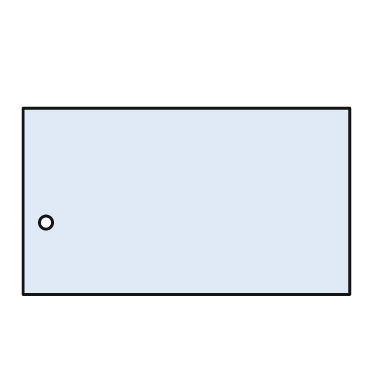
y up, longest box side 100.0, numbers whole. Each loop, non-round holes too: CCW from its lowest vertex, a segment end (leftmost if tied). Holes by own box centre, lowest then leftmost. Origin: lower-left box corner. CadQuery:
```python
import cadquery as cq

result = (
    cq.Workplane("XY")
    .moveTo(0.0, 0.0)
    .lineTo(100.0, 0.0)
    .lineTo(100.0, 57.0)
    .lineTo(0.0, 57.0)
    .close()
    .moveTo(7.0, 22.0)
    .circle(2.0)
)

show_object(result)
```